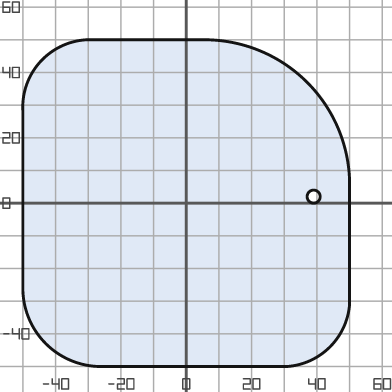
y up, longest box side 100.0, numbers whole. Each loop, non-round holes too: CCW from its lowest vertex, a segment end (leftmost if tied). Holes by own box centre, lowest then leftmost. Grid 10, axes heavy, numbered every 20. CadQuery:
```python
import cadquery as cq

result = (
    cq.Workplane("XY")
    .moveTo(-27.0, -50.0)
    .lineTo(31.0, -50.0)
    .threePointArc((44.0, -44.0), (50.0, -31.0))
    .lineTo(50.0, 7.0)
    .threePointArc((37.0, 37.0), (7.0, 50.0))
    .lineTo(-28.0, 50.0)
    .threePointArc((-44.0, 44.0), (-50.0, 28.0))
    .lineTo(-50.0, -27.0)
    .threePointArc((-43.0, -43.0), (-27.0, -50.0))
    .close()
    .moveTo(39.0, 2.0)
    .circle(2.0)
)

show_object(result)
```